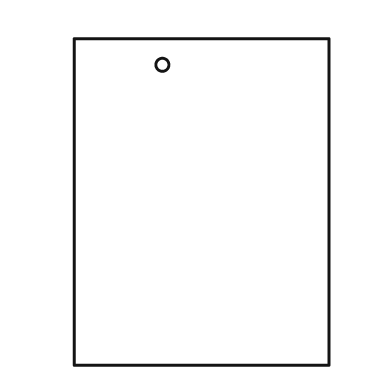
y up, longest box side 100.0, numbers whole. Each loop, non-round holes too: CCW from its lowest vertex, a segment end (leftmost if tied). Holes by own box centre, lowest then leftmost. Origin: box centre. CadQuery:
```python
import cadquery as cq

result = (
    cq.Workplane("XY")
    .moveTo(-39.0, -50.0)
    .lineTo(39.0, -50.0)
    .lineTo(39.0, 50.0)
    .lineTo(-39.0, 50.0)
    .close()
    .moveTo(-12.0, 42.0)
    .circle(2.0)
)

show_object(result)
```